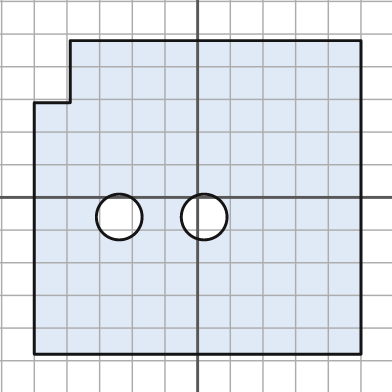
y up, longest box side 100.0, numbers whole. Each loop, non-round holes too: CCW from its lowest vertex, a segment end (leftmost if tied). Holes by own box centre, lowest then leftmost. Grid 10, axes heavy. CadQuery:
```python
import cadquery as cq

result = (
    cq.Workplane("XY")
    .moveTo(-50.0, -48.0)
    .lineTo(50.0, -48.0)
    .lineTo(50.0, 48.0)
    .lineTo(-39.0, 48.0)
    .lineTo(-39.0, 29.0)
    .lineTo(-50.0, 29.0)
    .close()
    .moveTo(-24.0, -6.0)
    .circle(7.0)
    .moveTo(2.0, -6.0)
    .circle(7.0)
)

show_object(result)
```